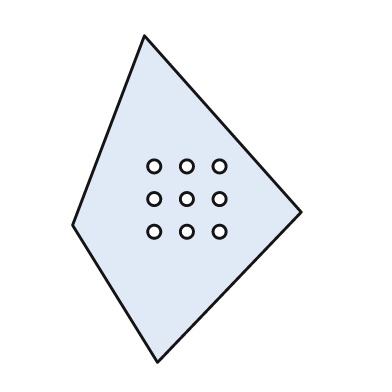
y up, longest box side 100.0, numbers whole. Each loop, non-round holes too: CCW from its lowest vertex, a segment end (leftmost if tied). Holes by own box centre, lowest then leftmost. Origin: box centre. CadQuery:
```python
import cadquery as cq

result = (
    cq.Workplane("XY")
    .moveTo(-9.0, -50.0)
    .lineTo(35.0, -4.0)
    .lineTo(-13.0, 50.0)
    .lineTo(-35.0, -8.0)
    .close()
    .moveTo(-10.0, -10.0)
    .circle(2.0)
    .moveTo(0.0, -10.0)
    .circle(2.0)
    .moveTo(10.0, -10.0)
    .circle(2.0)
    .moveTo(-10.0, 0.0)
    .circle(2.0)
    .moveTo(0.0, 0.0)
    .circle(2.0)
    .moveTo(10.0, 0.0)
    .circle(2.0)
    .moveTo(-10.0, 10.0)
    .circle(2.0)
    .moveTo(0.0, 10.0)
    .circle(2.0)
    .moveTo(10.0, 10.0)
    .circle(2.0)
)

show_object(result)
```